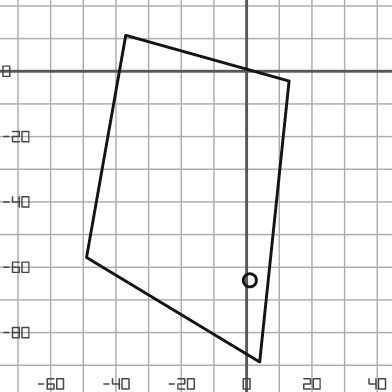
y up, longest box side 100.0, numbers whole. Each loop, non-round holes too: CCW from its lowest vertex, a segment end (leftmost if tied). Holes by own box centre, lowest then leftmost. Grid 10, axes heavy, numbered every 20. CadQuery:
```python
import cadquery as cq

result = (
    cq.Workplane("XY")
    .moveTo(4.0, -89.0)
    .lineTo(13.0, -3.0)
    .lineTo(-37.0, 11.0)
    .lineTo(-49.0, -57.0)
    .close()
    .moveTo(1.0, -64.0)
    .circle(2.0)
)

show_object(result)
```